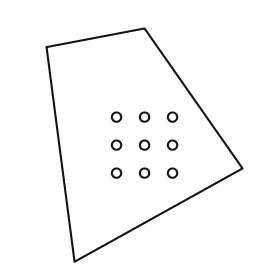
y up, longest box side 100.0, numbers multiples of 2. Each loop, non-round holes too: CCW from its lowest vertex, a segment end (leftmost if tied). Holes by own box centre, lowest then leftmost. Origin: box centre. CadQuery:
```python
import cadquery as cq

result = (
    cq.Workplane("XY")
    .moveTo(-30.0, -50.0)
    .lineTo(42.0, -10.0)
    .lineTo(0.0, 50.0)
    .lineTo(-42.0, 42.0)
    .close()
    .moveTo(-12.0, -12.0)
    .circle(2.0)
    .moveTo(0.0, -12.0)
    .circle(2.0)
    .moveTo(12.0, -12.0)
    .circle(2.0)
    .moveTo(-12.0, 0.0)
    .circle(2.0)
    .moveTo(0.0, 0.0)
    .circle(2.0)
    .moveTo(12.0, 0.0)
    .circle(2.0)
    .moveTo(-12.0, 12.0)
    .circle(2.0)
    .moveTo(0.0, 12.0)
    .circle(2.0)
    .moveTo(12.0, 12.0)
    .circle(2.0)
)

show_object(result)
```